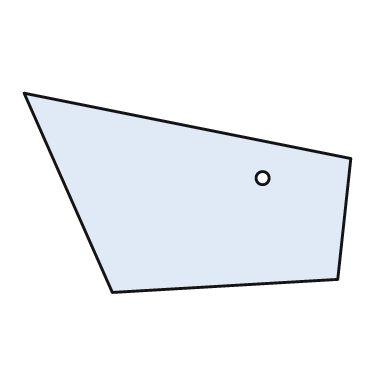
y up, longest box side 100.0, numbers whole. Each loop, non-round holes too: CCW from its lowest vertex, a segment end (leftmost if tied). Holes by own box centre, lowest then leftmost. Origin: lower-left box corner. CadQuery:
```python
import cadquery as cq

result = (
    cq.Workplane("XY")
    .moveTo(27.0, 0.0)
    .lineTo(96.0, 4.0)
    .lineTo(100.0, 41.0)
    .lineTo(0.0, 61.0)
    .close()
    .moveTo(73.0, 35.0)
    .circle(2.0)
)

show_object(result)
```